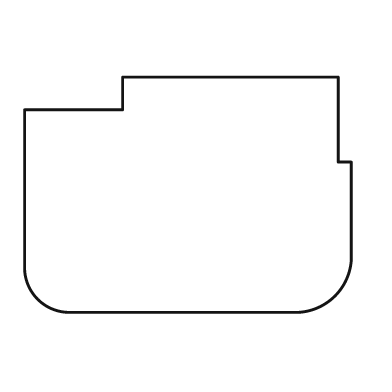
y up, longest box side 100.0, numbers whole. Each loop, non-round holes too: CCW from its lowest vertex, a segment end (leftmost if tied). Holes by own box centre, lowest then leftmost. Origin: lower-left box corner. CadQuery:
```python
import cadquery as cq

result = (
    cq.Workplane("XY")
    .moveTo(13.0, 0.0)
    .lineTo(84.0, 0.0)
    .threePointArc((95.0, 5.0), (100.0, 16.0))
    .lineTo(100.0, 46.0)
    .lineTo(96.0, 46.0)
    .lineTo(96.0, 72.0)
    .lineTo(30.0, 72.0)
    .lineTo(30.0, 62.0)
    .lineTo(0.0, 62.0)
    .lineTo(0.0, 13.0)
    .threePointArc((4.0, 4.0), (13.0, 0.0))
    .close()
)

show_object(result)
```